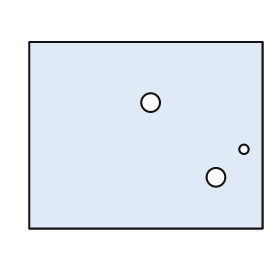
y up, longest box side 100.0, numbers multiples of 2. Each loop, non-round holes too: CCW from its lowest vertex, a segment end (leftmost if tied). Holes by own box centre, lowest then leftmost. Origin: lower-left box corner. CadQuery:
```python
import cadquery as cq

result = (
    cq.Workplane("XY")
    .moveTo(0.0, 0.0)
    .lineTo(100.0, 0.0)
    .lineTo(100.0, 80.0)
    .lineTo(0.0, 80.0)
    .close()
    .moveTo(80.0, 22.0)
    .circle(4.0)
    .moveTo(92.0, 34.0)
    .circle(2.0)
    .moveTo(52.0, 54.0)
    .circle(4.0)
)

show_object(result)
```